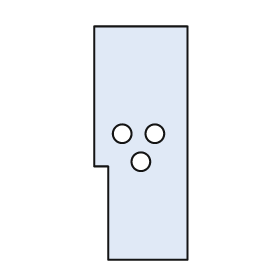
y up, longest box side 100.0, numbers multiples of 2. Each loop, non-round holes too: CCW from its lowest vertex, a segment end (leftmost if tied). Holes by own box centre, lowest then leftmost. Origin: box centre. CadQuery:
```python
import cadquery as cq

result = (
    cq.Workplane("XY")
    .moveTo(-14.0, -50.0)
    .lineTo(20.0, -50.0)
    .lineTo(20.0, 50.0)
    .lineTo(-20.0, 50.0)
    .lineTo(-20.0, -10.0)
    .lineTo(-14.0, -10.0)
    .close()
    .moveTo(0.0, -8.0)
    .circle(4.0)
    .moveTo(-8.0, 4.0)
    .circle(4.0)
    .moveTo(6.0, 4.0)
    .circle(4.0)
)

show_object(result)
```